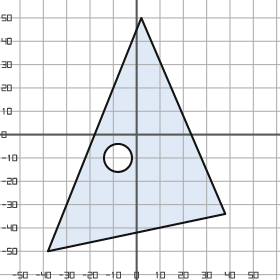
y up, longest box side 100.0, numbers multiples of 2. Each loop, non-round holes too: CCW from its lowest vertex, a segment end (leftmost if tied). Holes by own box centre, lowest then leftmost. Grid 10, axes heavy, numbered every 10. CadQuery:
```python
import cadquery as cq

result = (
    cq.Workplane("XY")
    .moveTo(-38.0, -50.0)
    .lineTo(38.0, -34.0)
    .lineTo(2.0, 50.0)
    .close()
    .moveTo(-8.0, -10.0)
    .circle(6.0)
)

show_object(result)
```